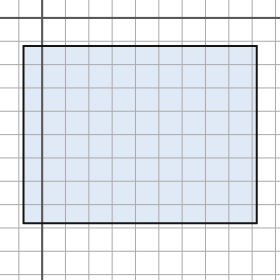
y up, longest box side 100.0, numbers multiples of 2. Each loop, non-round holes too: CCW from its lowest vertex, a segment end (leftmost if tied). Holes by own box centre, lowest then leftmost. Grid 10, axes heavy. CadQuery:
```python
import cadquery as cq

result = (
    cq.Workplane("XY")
    .moveTo(-8.0, -88.0)
    .lineTo(92.0, -88.0)
    .lineTo(92.0, -12.0)
    .lineTo(-8.0, -12.0)
    .close()
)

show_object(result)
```